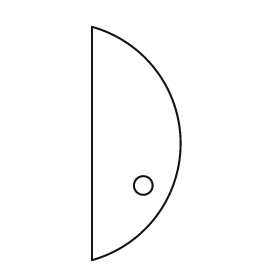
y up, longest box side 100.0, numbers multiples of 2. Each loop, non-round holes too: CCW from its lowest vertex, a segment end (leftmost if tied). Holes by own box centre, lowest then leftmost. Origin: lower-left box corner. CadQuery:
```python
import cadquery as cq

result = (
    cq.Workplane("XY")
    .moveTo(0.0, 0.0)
    .threePointArc((38.0, 50.0), (0.0, 100.0))
    .close()
    .moveTo(22.0, 32.0)
    .circle(4.0)
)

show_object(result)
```